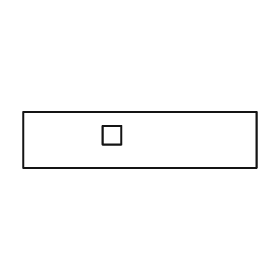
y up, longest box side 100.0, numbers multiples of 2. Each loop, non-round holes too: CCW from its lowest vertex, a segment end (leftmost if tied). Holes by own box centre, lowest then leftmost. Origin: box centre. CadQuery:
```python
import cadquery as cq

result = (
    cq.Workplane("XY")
    .moveTo(-50.0, -12.0)
    .lineTo(50.0, -12.0)
    .lineTo(50.0, 12.0)
    .lineTo(-50.0, 12.0)
    .close()
    .moveTo(-16.0, -2.0)
    .lineTo(-8.0, -2.0)
    .lineTo(-8.0, 6.0)
    .lineTo(-16.0, 6.0)
    .close()
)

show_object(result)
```